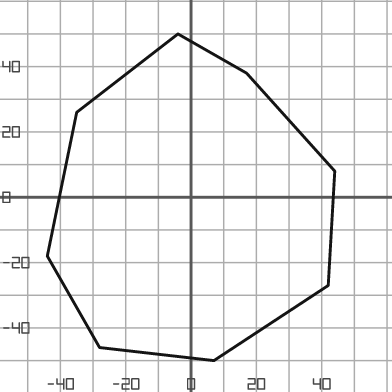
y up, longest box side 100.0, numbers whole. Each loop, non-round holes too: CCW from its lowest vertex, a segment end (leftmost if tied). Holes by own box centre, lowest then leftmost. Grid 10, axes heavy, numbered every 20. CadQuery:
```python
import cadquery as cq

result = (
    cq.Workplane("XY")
    .moveTo(7.0, -50.0)
    .lineTo(42.0, -27.0)
    .lineTo(44.0, 8.0)
    .lineTo(17.0, 38.0)
    .lineTo(-4.0, 50.0)
    .lineTo(-35.0, 26.0)
    .lineTo(-44.0, -18.0)
    .lineTo(-28.0, -46.0)
    .close()
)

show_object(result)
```